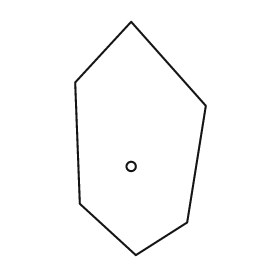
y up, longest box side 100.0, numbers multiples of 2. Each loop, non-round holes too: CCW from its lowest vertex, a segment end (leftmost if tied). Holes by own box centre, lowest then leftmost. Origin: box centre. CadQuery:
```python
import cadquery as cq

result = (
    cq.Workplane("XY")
    .moveTo(-2.0, -50.0)
    .lineTo(20.0, -36.0)
    .lineTo(28.0, 14.0)
    .lineTo(-4.0, 50.0)
    .lineTo(-28.0, 24.0)
    .lineTo(-26.0, -28.0)
    .close()
    .moveTo(-4.0, -12.0)
    .circle(2.0)
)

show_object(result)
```